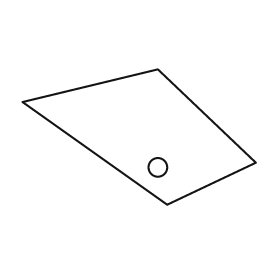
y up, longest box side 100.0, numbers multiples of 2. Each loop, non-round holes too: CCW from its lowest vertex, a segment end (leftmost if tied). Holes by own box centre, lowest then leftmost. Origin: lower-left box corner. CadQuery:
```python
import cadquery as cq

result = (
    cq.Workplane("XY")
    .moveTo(62.0, 0.0)
    .lineTo(100.0, 18.0)
    .lineTo(58.0, 58.0)
    .lineTo(0.0, 44.0)
    .close()
    .moveTo(58.0, 16.0)
    .circle(4.0)
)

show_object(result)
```